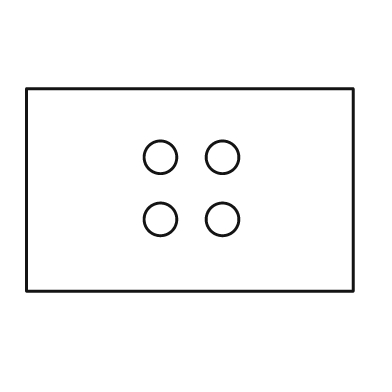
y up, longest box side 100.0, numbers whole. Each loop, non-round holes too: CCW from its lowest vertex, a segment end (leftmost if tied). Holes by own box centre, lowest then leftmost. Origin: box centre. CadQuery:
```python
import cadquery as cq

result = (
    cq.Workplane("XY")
    .moveTo(-50.0, -31.0)
    .lineTo(50.0, -31.0)
    .lineTo(50.0, 31.0)
    .lineTo(-50.0, 31.0)
    .close()
    .moveTo(-9.0, -9.0)
    .circle(5.0)
    .moveTo(10.0, -9.0)
    .circle(5.0)
    .moveTo(-9.0, 10.0)
    .circle(5.0)
    .moveTo(10.0, 10.0)
    .circle(5.0)
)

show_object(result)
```